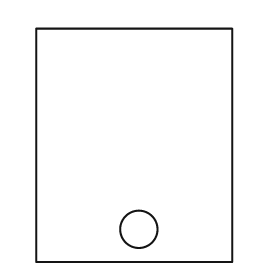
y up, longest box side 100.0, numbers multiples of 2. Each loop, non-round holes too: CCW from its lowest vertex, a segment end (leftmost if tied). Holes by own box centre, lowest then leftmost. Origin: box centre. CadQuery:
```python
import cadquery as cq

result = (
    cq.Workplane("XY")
    .moveTo(-42.0, -50.0)
    .lineTo(42.0, -50.0)
    .lineTo(42.0, 50.0)
    .lineTo(-42.0, 50.0)
    .close()
    .moveTo(2.0, -36.0)
    .circle(8.0)
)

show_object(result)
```